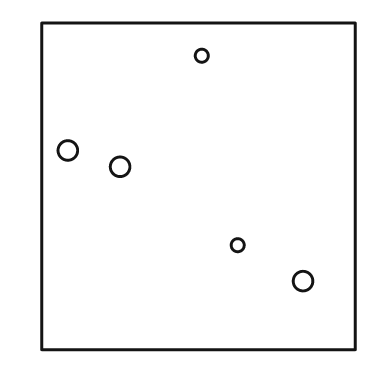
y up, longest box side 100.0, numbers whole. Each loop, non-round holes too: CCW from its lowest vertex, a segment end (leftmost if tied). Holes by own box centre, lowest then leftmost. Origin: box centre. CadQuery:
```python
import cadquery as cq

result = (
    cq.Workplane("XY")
    .moveTo(-48.0, -50.0)
    .lineTo(48.0, -50.0)
    .lineTo(48.0, 50.0)
    .lineTo(-48.0, 50.0)
    .close()
    .moveTo(32.0, -29.0)
    .circle(3.0)
    .moveTo(12.0, -18.0)
    .circle(2.0)
    .moveTo(-24.0, 6.0)
    .circle(3.0)
    .moveTo(-40.0, 11.0)
    .circle(3.0)
    .moveTo(1.0, 40.0)
    .circle(2.0)
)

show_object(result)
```